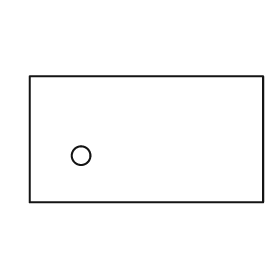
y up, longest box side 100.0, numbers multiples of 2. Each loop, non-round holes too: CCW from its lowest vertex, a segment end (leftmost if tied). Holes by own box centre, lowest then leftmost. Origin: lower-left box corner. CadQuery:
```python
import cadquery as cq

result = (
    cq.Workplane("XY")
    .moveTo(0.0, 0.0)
    .lineTo(100.0, 0.0)
    .lineTo(100.0, 54.0)
    .lineTo(0.0, 54.0)
    .close()
    .moveTo(22.0, 20.0)
    .circle(4.0)
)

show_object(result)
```